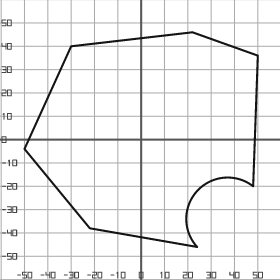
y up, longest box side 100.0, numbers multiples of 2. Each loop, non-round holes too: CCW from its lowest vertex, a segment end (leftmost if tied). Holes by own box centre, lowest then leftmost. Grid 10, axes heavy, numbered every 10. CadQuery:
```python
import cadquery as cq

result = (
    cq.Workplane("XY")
    .moveTo(24.0, -46.0)
    .threePointArc((24.0, -22.0), (48.0, -20.0))
    .lineTo(50.0, 36.0)
    .lineTo(22.0, 46.0)
    .lineTo(-30.0, 40.0)
    .lineTo(-50.0, -4.0)
    .lineTo(-22.0, -38.0)
    .close()
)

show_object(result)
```